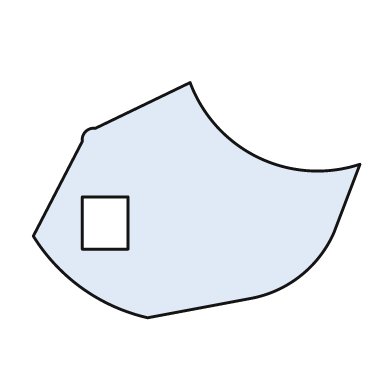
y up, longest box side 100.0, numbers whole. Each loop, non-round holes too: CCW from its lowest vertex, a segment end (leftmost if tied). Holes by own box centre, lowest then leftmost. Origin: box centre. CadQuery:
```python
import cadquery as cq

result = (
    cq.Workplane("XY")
    .moveTo(-15.0, -36.0)
    .lineTo(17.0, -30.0)
    .threePointArc((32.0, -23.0), (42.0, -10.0))
    .lineTo(50.0, 11.0)
    .threePointArc((19.0, 13.0), (-2.0, 36.0))
    .lineTo(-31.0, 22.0)
    .threePointArc((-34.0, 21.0), (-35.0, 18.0))
    .lineTo(-50.0, -11.0)
    .threePointArc((-35.0, -27.0), (-15.0, -36.0))
    .close()
    .moveTo(-35.0, -15.0)
    .lineTo(-21.0, -15.0)
    .lineTo(-21.0, 1.0)
    .lineTo(-35.0, 1.0)
    .close()
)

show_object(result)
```